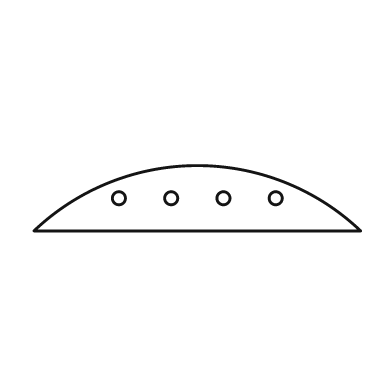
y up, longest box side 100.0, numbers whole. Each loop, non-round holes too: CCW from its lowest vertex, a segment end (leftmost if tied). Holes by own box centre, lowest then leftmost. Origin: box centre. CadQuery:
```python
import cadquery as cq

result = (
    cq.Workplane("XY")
    .moveTo(-50.0, -10.0)
    .lineTo(50.0, -10.0)
    .threePointArc((0.0, 10.0), (-50.0, -10.0))
    .close()
    .moveTo(-24.0, 0.0)
    .circle(2.0)
    .moveTo(-8.0, 0.0)
    .circle(2.0)
    .moveTo(8.0, 0.0)
    .circle(2.0)
    .moveTo(24.0, 0.0)
    .circle(2.0)
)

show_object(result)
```